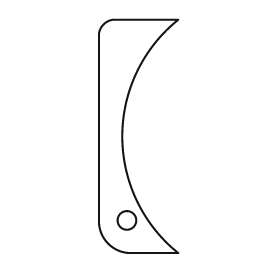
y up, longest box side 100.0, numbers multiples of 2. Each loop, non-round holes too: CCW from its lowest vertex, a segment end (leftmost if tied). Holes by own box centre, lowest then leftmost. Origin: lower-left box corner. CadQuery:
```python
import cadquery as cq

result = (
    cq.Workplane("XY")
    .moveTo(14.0, 0.0)
    .lineTo(34.0, 0.0)
    .threePointArc((10.0, 50.0), (34.0, 100.0))
    .lineTo(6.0, 100.0)
    .threePointArc((2.0, 98.0), (0.0, 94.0))
    .lineTo(0.0, 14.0)
    .threePointArc((4.0, 4.0), (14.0, 0.0))
    .close()
    .moveTo(12.0, 14.0)
    .circle(4.0)
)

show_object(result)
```